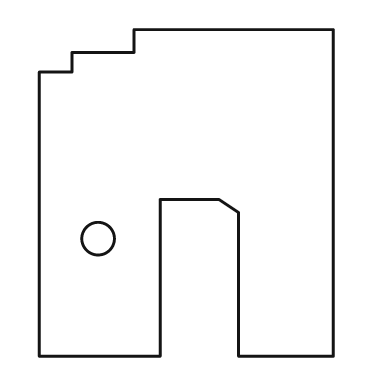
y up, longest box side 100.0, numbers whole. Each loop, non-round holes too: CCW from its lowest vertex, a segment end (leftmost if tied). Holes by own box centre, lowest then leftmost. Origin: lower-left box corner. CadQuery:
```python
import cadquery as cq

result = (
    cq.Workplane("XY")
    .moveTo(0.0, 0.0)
    .lineTo(37.0, 0.0)
    .lineTo(37.0, 48.0)
    .lineTo(55.0, 48.0)
    .lineTo(61.0, 44.0)
    .lineTo(61.0, 0.0)
    .lineTo(90.0, 0.0)
    .lineTo(90.0, 100.0)
    .lineTo(29.0, 100.0)
    .lineTo(29.0, 93.0)
    .lineTo(10.0, 93.0)
    .lineTo(10.0, 87.0)
    .lineTo(0.0, 87.0)
    .close()
    .moveTo(18.0, 36.0)
    .circle(5.0)
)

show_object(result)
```